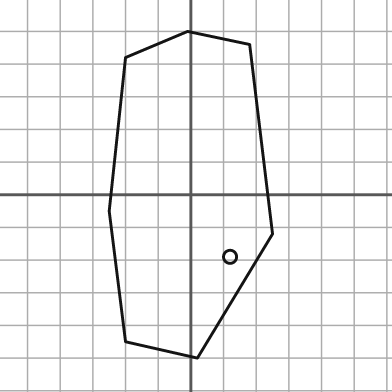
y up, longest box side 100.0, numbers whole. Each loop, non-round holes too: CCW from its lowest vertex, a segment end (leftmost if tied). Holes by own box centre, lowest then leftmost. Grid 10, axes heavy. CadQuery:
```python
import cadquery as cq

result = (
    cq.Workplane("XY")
    .moveTo(2.0, -50.0)
    .lineTo(25.0, -12.0)
    .lineTo(18.0, 46.0)
    .lineTo(-1.0, 50.0)
    .lineTo(-20.0, 42.0)
    .lineTo(-25.0, -5.0)
    .lineTo(-20.0, -45.0)
    .close()
    .moveTo(12.0, -19.0)
    .circle(2.0)
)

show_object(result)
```